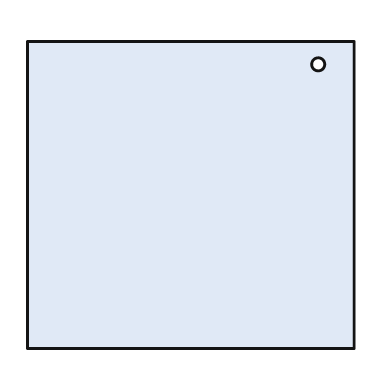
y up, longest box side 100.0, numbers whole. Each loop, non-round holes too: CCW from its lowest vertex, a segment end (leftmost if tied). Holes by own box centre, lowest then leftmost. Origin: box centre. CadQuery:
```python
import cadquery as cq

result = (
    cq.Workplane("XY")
    .moveTo(-50.0, -47.0)
    .lineTo(50.0, -47.0)
    .lineTo(50.0, 47.0)
    .lineTo(-50.0, 47.0)
    .close()
    .moveTo(39.0, 40.0)
    .circle(2.0)
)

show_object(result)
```